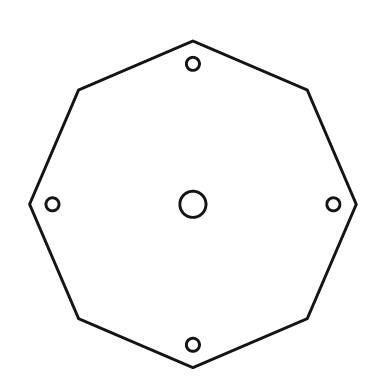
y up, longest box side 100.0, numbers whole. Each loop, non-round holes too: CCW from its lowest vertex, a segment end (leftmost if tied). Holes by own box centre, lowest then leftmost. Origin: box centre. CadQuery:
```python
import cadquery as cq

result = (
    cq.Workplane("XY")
    .moveTo(0.0, -50.0)
    .lineTo(35.0, -35.0)
    .lineTo(50.0, 0.0)
    .lineTo(35.0, 35.0)
    .lineTo(0.0, 50.0)
    .lineTo(-35.0, 35.0)
    .lineTo(-50.0, 0.0)
    .lineTo(-35.0, -35.0)
    .close()
    .moveTo(0.0, -43.0)
    .circle(2.0)
    .moveTo(-43.0, 0.0)
    .circle(2.0)
    .moveTo(0.0, 0.0)
    .circle(4.0)
    .moveTo(43.0, 0.0)
    .circle(2.0)
    .moveTo(0.0, 43.0)
    .circle(2.0)
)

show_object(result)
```